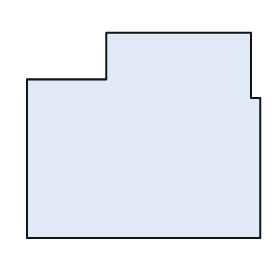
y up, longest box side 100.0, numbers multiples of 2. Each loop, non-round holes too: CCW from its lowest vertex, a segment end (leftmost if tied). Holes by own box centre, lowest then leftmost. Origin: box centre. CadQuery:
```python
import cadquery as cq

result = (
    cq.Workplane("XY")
    .moveTo(-50.0, -44.0)
    .lineTo(50.0, -44.0)
    .lineTo(50.0, 16.0)
    .lineTo(46.0, 16.0)
    .lineTo(46.0, 44.0)
    .lineTo(-16.0, 44.0)
    .lineTo(-16.0, 24.0)
    .lineTo(-50.0, 24.0)
    .close()
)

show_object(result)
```